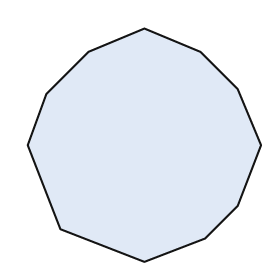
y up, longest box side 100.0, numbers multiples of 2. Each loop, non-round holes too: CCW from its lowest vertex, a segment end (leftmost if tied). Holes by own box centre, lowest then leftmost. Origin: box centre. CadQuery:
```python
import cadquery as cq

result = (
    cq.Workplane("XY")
    .moveTo(0.0, -50.0)
    .lineTo(26.0, -40.0)
    .lineTo(40.0, -26.0)
    .lineTo(50.0, 0.0)
    .lineTo(40.0, 24.0)
    .lineTo(24.0, 40.0)
    .lineTo(0.0, 50.0)
    .lineTo(-24.0, 40.0)
    .lineTo(-42.0, 22.0)
    .lineTo(-50.0, 0.0)
    .lineTo(-36.0, -36.0)
    .close()
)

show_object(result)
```